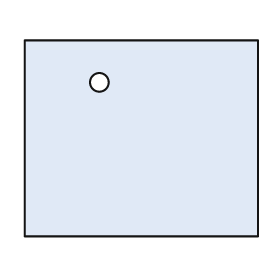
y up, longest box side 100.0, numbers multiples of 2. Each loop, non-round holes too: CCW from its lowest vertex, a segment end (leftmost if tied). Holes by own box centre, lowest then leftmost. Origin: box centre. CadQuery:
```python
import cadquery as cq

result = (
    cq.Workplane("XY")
    .moveTo(-50.0, -42.0)
    .lineTo(50.0, -42.0)
    .lineTo(50.0, 42.0)
    .lineTo(-50.0, 42.0)
    .close()
    .moveTo(-18.0, 24.0)
    .circle(4.0)
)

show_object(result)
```